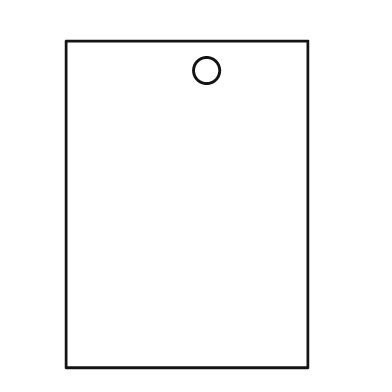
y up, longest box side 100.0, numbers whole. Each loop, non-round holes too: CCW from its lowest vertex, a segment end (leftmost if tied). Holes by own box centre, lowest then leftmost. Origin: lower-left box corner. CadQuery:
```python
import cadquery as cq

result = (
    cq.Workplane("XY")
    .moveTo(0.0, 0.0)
    .lineTo(74.0, 0.0)
    .lineTo(74.0, 100.0)
    .lineTo(0.0, 100.0)
    .close()
    .moveTo(43.0, 91.0)
    .circle(4.0)
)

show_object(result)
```